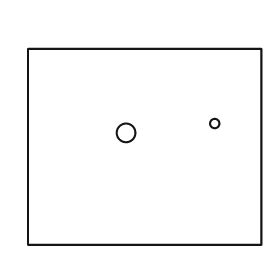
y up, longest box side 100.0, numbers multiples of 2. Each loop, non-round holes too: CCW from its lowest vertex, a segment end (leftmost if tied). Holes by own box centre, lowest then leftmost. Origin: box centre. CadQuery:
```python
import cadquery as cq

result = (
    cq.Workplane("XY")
    .moveTo(-50.0, -42.0)
    .lineTo(50.0, -42.0)
    .lineTo(50.0, 42.0)
    .lineTo(-50.0, 42.0)
    .close()
    .moveTo(-8.0, 6.0)
    .circle(4.0)
    .moveTo(30.0, 10.0)
    .circle(2.0)
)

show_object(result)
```